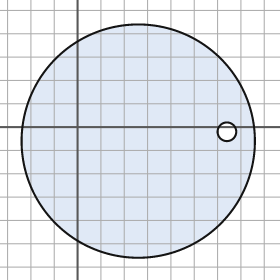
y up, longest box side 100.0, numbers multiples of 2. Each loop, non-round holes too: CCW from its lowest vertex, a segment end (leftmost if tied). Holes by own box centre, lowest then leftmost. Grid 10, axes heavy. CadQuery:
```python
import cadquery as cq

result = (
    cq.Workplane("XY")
    .moveTo(26.0, -6.0)
    .circle(50.0)
    .moveTo(64.0, -2.0)
    .circle(4.0)
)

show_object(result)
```